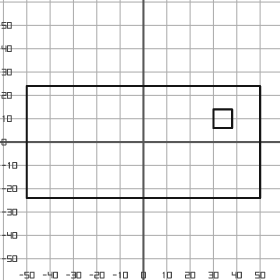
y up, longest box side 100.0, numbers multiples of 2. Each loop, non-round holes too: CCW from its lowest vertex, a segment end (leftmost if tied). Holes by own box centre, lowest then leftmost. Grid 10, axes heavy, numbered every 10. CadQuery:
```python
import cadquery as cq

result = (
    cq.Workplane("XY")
    .moveTo(-50.0, -24.0)
    .lineTo(50.0, -24.0)
    .lineTo(50.0, 24.0)
    .lineTo(-50.0, 24.0)
    .close()
    .moveTo(30.0, 6.0)
    .lineTo(38.0, 6.0)
    .lineTo(38.0, 14.0)
    .lineTo(30.0, 14.0)
    .close()
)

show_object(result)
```